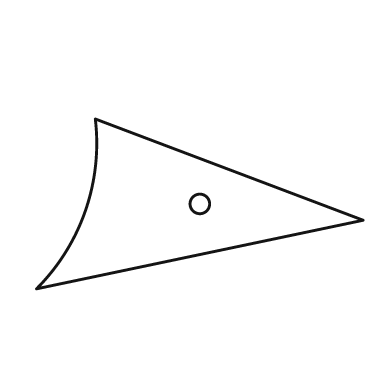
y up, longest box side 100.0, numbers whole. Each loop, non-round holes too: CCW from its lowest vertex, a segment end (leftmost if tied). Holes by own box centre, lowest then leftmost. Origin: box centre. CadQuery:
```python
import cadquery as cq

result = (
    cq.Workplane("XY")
    .moveTo(-50.0, -26.0)
    .lineTo(50.0, -5.0)
    .lineTo(-32.0, 26.0)
    .threePointArc((-35.0, -2.0), (-50.0, -26.0))
    .close()
    .moveTo(0.0, 0.0)
    .circle(3.0)
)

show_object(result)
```